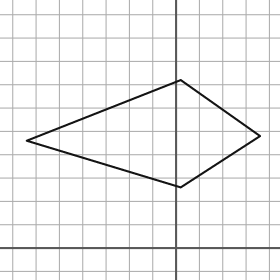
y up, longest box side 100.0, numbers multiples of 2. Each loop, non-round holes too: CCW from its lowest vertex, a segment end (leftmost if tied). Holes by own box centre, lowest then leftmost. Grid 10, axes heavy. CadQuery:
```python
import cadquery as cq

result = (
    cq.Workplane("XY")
    .moveTo(2.0, 26.0)
    .lineTo(36.0, 48.0)
    .lineTo(2.0, 72.0)
    .lineTo(-64.0, 46.0)
    .close()
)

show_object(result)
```